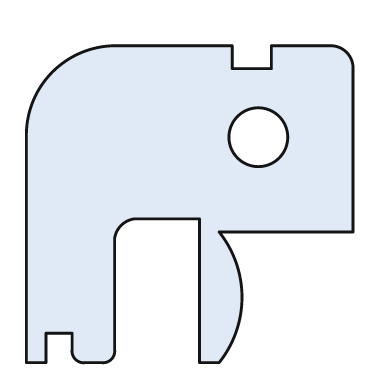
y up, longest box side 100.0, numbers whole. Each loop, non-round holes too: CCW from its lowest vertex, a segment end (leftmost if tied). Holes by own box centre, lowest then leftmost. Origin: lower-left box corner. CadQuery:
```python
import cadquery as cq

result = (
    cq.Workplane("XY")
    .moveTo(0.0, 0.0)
    .lineTo(6.0, 0.0)
    .lineTo(6.0, 9.0)
    .lineTo(14.0, 9.0)
    .lineTo(14.0, 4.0)
    .threePointArc((15.0, 1.0), (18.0, 0.0))
    .lineTo(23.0, 0.0)
    .threePointArc((26.0, 1.0), (27.0, 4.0))
    .lineTo(27.0, 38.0)
    .threePointArc((29.0, 42.0), (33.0, 44.0))
    .lineTo(53.0, 44.0)
    .lineTo(53.0, 0.0)
    .lineTo(59.0, 0.0)
    .threePointArc((66.0, 20.0), (59.0, 40.0))
    .lineTo(100.0, 40.0)
    .lineTo(100.0, 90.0)
    .threePointArc((98.0, 95.0), (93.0, 97.0))
    .lineTo(75.0, 97.0)
    .lineTo(75.0, 90.0)
    .lineTo(63.0, 90.0)
    .lineTo(63.0, 97.0)
    .lineTo(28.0, 97.0)
    .threePointArc((8.0, 89.0), (0.0, 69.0))
    .close()
    .moveTo(71.0, 69.0)
    .circle(9.0)
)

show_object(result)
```